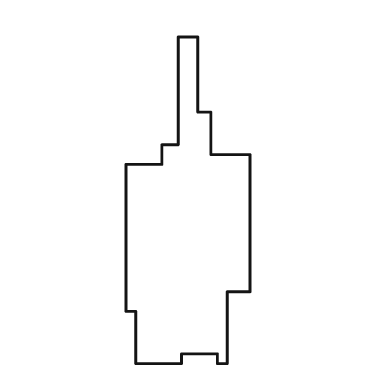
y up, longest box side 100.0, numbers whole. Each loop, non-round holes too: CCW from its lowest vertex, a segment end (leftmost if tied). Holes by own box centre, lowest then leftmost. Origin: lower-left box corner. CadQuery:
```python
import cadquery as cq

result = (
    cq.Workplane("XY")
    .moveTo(3.0, 0.0)
    .lineTo(17.0, 0.0)
    .lineTo(17.0, 3.0)
    .lineTo(28.0, 3.0)
    .lineTo(28.0, 0.0)
    .lineTo(31.0, 0.0)
    .lineTo(31.0, 22.0)
    .lineTo(38.0, 22.0)
    .lineTo(38.0, 64.0)
    .lineTo(26.0, 64.0)
    .lineTo(26.0, 77.0)
    .lineTo(22.0, 77.0)
    .lineTo(22.0, 100.0)
    .lineTo(16.0, 100.0)
    .lineTo(16.0, 67.0)
    .lineTo(11.0, 67.0)
    .lineTo(11.0, 61.0)
    .lineTo(0.0, 61.0)
    .lineTo(0.0, 16.0)
    .lineTo(3.0, 16.0)
    .close()
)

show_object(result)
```